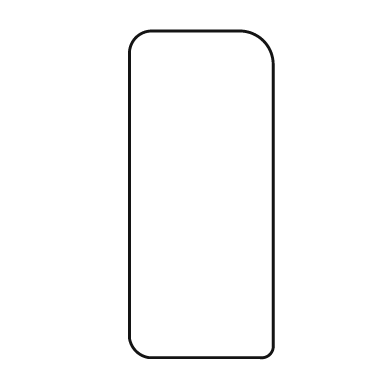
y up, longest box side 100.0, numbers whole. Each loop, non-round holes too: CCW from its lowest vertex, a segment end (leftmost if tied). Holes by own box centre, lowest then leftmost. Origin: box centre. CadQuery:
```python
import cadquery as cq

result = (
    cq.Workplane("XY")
    .moveTo(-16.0, -50.0)
    .lineTo(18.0, -50.0)
    .threePointArc((21.0, -49.0), (22.0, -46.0))
    .lineTo(22.0, 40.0)
    .threePointArc((19.0, 47.0), (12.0, 50.0))
    .lineTo(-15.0, 50.0)
    .threePointArc((-20.0, 48.0), (-22.0, 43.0))
    .lineTo(-22.0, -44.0)
    .threePointArc((-20.0, -48.0), (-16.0, -50.0))
    .close()
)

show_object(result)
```